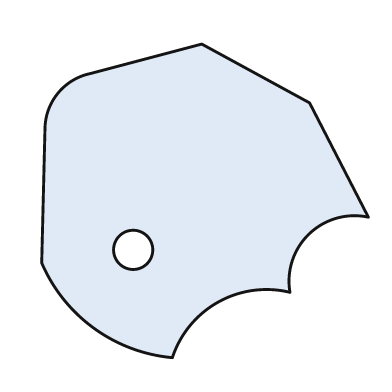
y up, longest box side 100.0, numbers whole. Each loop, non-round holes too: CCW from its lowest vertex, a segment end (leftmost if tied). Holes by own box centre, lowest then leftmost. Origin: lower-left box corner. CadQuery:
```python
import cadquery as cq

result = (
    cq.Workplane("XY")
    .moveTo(40.0, 0.0)
    .threePointArc((54.0, 17.0), (76.0, 20.0))
    .threePointArc((82.0, 38.0), (100.0, 43.0))
    .lineTo(82.0, 78.0)
    .lineTo(49.0, 96.0)
    .lineTo(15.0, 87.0)
    .threePointArc((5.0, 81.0), (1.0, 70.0))
    .lineTo(0.0, 29.0)
    .threePointArc((16.0, 9.0), (40.0, 0.0))
    .close()
    .moveTo(28.0, 33.0)
    .circle(6.0)
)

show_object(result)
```